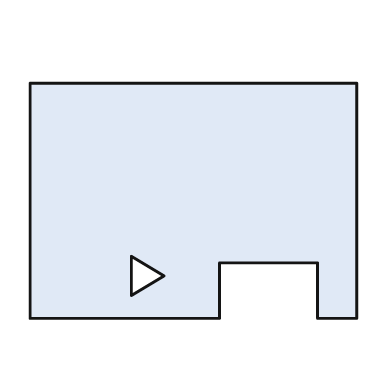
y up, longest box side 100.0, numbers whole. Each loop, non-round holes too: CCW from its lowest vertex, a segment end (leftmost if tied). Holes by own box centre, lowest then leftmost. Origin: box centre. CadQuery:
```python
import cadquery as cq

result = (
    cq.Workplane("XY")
    .moveTo(-50.0, -36.0)
    .lineTo(8.0, -36.0)
    .lineTo(8.0, -19.0)
    .lineTo(38.0, -19.0)
    .lineTo(38.0, -36.0)
    .lineTo(50.0, -36.0)
    .lineTo(50.0, 36.0)
    .lineTo(-50.0, 36.0)
    .close()
    .moveTo(-19.0, -29.0)
    .lineTo(-9.0, -23.0)
    .lineTo(-19.0, -17.0)
    .close()
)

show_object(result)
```